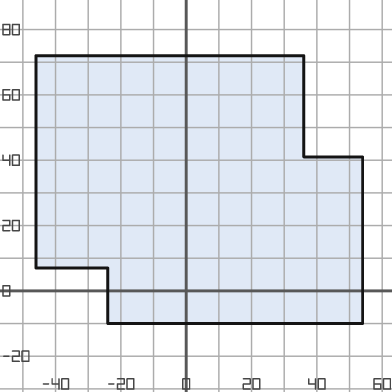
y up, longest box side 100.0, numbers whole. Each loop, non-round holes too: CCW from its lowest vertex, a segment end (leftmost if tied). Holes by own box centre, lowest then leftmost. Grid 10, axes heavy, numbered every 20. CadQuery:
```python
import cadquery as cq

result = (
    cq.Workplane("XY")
    .moveTo(-24.0, -10.0)
    .lineTo(54.0, -10.0)
    .lineTo(54.0, 41.0)
    .lineTo(36.0, 41.0)
    .lineTo(36.0, 72.0)
    .lineTo(-46.0, 72.0)
    .lineTo(-46.0, 7.0)
    .lineTo(-24.0, 7.0)
    .close()
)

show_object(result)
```